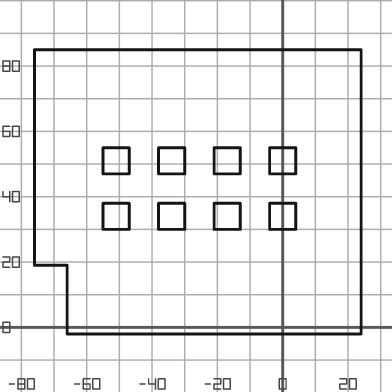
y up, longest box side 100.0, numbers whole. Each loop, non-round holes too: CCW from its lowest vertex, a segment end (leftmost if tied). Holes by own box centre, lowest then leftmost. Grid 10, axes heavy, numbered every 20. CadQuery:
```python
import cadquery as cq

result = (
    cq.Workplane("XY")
    .moveTo(-66.0, -2.0)
    .lineTo(24.0, -2.0)
    .lineTo(24.0, 85.0)
    .lineTo(-76.0, 85.0)
    .lineTo(-76.0, 19.0)
    .lineTo(-66.0, 19.0)
    .close()
    .moveTo(-55.0, 30.0)
    .lineTo(-47.0, 30.0)
    .lineTo(-47.0, 38.0)
    .lineTo(-55.0, 38.0)
    .close()
    .moveTo(-38.0, 30.0)
    .lineTo(-30.0, 30.0)
    .lineTo(-30.0, 38.0)
    .lineTo(-38.0, 38.0)
    .close()
    .moveTo(-21.0, 30.0)
    .lineTo(-13.0, 30.0)
    .lineTo(-13.0, 38.0)
    .lineTo(-21.0, 38.0)
    .close()
    .moveTo(-4.0, 30.0)
    .lineTo(4.0, 30.0)
    .lineTo(4.0, 38.0)
    .lineTo(-4.0, 38.0)
    .close()
    .moveTo(-55.0, 47.0)
    .lineTo(-47.0, 47.0)
    .lineTo(-47.0, 55.0)
    .lineTo(-55.0, 55.0)
    .close()
    .moveTo(-38.0, 47.0)
    .lineTo(-30.0, 47.0)
    .lineTo(-30.0, 55.0)
    .lineTo(-38.0, 55.0)
    .close()
    .moveTo(-21.0, 47.0)
    .lineTo(-13.0, 47.0)
    .lineTo(-13.0, 55.0)
    .lineTo(-21.0, 55.0)
    .close()
    .moveTo(-4.0, 47.0)
    .lineTo(4.0, 47.0)
    .lineTo(4.0, 55.0)
    .lineTo(-4.0, 55.0)
    .close()
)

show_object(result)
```